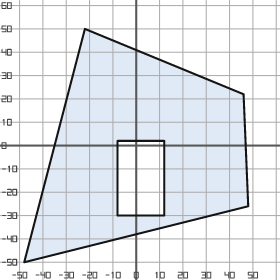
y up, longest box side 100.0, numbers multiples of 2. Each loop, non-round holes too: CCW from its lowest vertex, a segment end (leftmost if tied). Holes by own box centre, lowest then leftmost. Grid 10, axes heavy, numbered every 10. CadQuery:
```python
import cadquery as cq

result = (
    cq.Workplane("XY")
    .moveTo(-48.0, -50.0)
    .lineTo(48.0, -26.0)
    .lineTo(46.0, 22.0)
    .lineTo(-22.0, 50.0)
    .close()
    .moveTo(-8.0, -30.0)
    .lineTo(12.0, -30.0)
    .lineTo(12.0, 2.0)
    .lineTo(-8.0, 2.0)
    .close()
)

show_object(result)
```